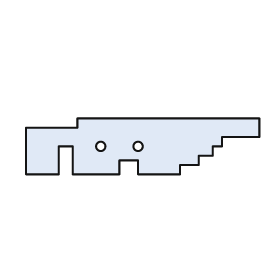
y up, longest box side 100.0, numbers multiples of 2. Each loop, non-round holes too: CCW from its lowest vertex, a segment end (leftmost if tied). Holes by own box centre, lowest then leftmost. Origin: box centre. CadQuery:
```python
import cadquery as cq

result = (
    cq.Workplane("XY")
    .moveTo(-50.0, -12.0)
    .lineTo(-36.0, -12.0)
    .lineTo(-36.0, 0.0)
    .lineTo(-30.0, 0.0)
    .lineTo(-30.0, -12.0)
    .lineTo(-10.0, -12.0)
    .lineTo(-10.0, -6.0)
    .lineTo(-2.0, -6.0)
    .lineTo(-2.0, -12.0)
    .lineTo(16.0, -12.0)
    .lineTo(16.0, -8.0)
    .lineTo(24.0, -8.0)
    .lineTo(24.0, -4.0)
    .lineTo(30.0, -4.0)
    .lineTo(30.0, 0.0)
    .lineTo(34.0, 0.0)
    .lineTo(34.0, 4.0)
    .lineTo(50.0, 4.0)
    .lineTo(50.0, 12.0)
    .lineTo(-28.0, 12.0)
    .lineTo(-28.0, 8.0)
    .lineTo(-50.0, 8.0)
    .close()
    .moveTo(-18.0, 0.0)
    .circle(2.0)
    .moveTo(-2.0, 0.0)
    .circle(2.0)
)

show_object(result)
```